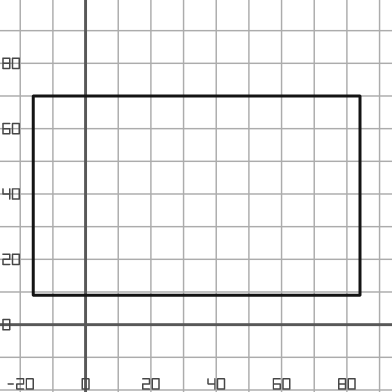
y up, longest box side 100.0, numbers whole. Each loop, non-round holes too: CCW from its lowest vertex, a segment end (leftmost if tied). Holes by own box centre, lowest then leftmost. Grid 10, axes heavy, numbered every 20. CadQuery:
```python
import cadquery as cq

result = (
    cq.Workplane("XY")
    .moveTo(-16.0, 9.0)
    .lineTo(84.0, 9.0)
    .lineTo(84.0, 70.0)
    .lineTo(-16.0, 70.0)
    .close()
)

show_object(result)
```